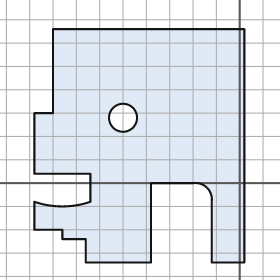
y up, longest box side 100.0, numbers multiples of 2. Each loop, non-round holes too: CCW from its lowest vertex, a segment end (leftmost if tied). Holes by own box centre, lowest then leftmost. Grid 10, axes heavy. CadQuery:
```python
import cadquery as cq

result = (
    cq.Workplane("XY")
    .moveTo(-66.0, -34.0)
    .lineTo(-38.0, -34.0)
    .lineTo(-38.0, 0.0)
    .lineTo(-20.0, 0.0)
    .threePointArc((-14.0, -2.0), (-12.0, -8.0))
    .lineTo(-12.0, -34.0)
    .lineTo(2.0, -34.0)
    .lineTo(2.0, 66.0)
    .lineTo(-80.0, 66.0)
    .lineTo(-80.0, 30.0)
    .lineTo(-88.0, 30.0)
    .lineTo(-88.0, 4.0)
    .lineTo(-64.0, 4.0)
    .lineTo(-64.0, -8.0)
    .threePointArc((-76.0, -10.0), (-88.0, -8.0))
    .lineTo(-88.0, -20.0)
    .lineTo(-76.0, -20.0)
    .lineTo(-76.0, -24.0)
    .lineTo(-66.0, -24.0)
    .close()
    .moveTo(-50.0, 28.0)
    .circle(6.0)
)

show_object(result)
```